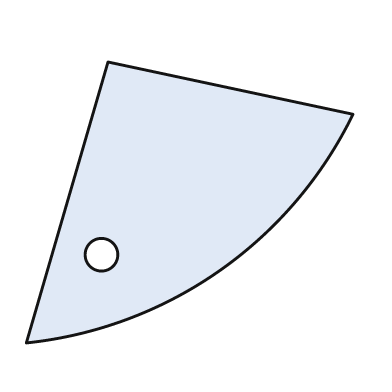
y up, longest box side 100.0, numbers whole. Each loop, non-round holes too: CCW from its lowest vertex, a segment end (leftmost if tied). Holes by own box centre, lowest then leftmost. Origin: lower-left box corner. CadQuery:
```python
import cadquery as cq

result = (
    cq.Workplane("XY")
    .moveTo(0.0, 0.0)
    .threePointArc((59.0, 22.0), (100.0, 70.0))
    .lineTo(25.0, 86.0)
    .close()
    .moveTo(23.0, 27.0)
    .circle(5.0)
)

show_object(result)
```